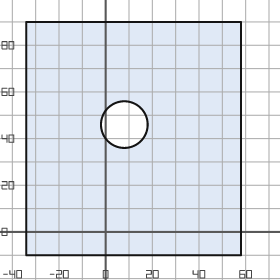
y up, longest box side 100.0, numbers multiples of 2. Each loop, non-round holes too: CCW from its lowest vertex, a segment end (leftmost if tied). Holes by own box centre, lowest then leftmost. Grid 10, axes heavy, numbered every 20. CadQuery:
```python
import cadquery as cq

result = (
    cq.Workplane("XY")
    .moveTo(-34.0, -10.0)
    .lineTo(58.0, -10.0)
    .lineTo(58.0, 90.0)
    .lineTo(-34.0, 90.0)
    .close()
    .moveTo(8.0, 46.0)
    .circle(10.0)
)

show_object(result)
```